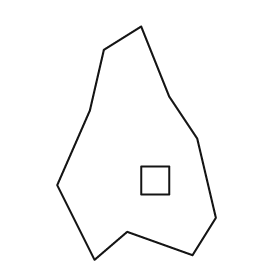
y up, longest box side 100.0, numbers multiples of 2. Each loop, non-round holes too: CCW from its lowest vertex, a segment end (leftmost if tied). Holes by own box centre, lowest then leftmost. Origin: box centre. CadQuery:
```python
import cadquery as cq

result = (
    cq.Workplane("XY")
    .moveTo(-18.0, -50.0)
    .lineTo(-4.0, -38.0)
    .lineTo(24.0, -48.0)
    .lineTo(34.0, -32.0)
    .lineTo(26.0, 2.0)
    .lineTo(14.0, 20.0)
    .lineTo(2.0, 50.0)
    .lineTo(-14.0, 40.0)
    .lineTo(-20.0, 14.0)
    .lineTo(-34.0, -18.0)
    .close()
    .moveTo(2.0, -22.0)
    .lineTo(14.0, -22.0)
    .lineTo(14.0, -10.0)
    .lineTo(2.0, -10.0)
    .close()
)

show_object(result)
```